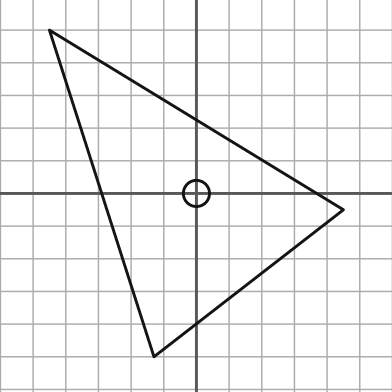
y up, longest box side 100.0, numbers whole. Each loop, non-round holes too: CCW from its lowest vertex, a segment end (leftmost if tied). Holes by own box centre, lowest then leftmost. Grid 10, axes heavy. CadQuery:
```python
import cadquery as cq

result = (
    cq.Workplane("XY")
    .moveTo(-13.0, -50.0)
    .lineTo(45.0, -5.0)
    .lineTo(-45.0, 50.0)
    .close()
    .moveTo(0.0, 0.0)
    .circle(4.0)
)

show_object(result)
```